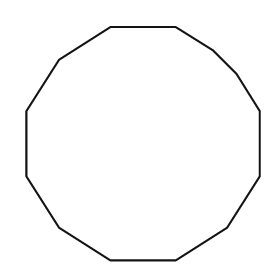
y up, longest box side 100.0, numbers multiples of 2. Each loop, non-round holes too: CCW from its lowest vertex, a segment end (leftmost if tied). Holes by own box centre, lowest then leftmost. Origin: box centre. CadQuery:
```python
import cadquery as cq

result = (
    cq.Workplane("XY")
    .moveTo(-14.0, -50.0)
    .lineTo(14.0, -50.0)
    .lineTo(36.0, -36.0)
    .lineTo(50.0, -14.0)
    .lineTo(50.0, 14.0)
    .lineTo(40.0, 30.0)
    .lineTo(30.0, 40.0)
    .lineTo(14.0, 50.0)
    .lineTo(-14.0, 50.0)
    .lineTo(-36.0, 36.0)
    .lineTo(-50.0, 14.0)
    .lineTo(-50.0, -14.0)
    .lineTo(-36.0, -36.0)
    .close()
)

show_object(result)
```